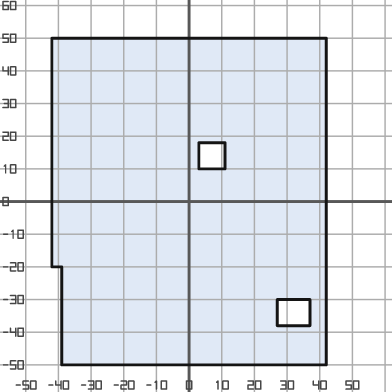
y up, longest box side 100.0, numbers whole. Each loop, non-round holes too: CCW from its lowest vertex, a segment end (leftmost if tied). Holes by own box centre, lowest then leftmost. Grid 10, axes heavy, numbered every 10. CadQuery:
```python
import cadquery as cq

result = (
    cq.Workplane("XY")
    .moveTo(-39.0, -50.0)
    .lineTo(42.0, -50.0)
    .lineTo(42.0, 50.0)
    .lineTo(-42.0, 50.0)
    .lineTo(-42.0, -20.0)
    .lineTo(-39.0, -20.0)
    .close()
    .moveTo(27.0, -38.0)
    .lineTo(37.0, -38.0)
    .lineTo(37.0, -30.0)
    .lineTo(27.0, -30.0)
    .close()
    .moveTo(3.0, 10.0)
    .lineTo(11.0, 10.0)
    .lineTo(11.0, 18.0)
    .lineTo(3.0, 18.0)
    .close()
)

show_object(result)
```